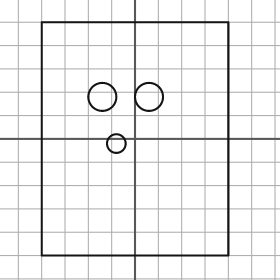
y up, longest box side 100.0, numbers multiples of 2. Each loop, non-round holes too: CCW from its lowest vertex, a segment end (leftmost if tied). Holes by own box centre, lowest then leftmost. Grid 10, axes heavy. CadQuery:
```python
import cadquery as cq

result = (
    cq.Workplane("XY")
    .moveTo(-40.0, -50.0)
    .lineTo(40.0, -50.0)
    .lineTo(40.0, 50.0)
    .lineTo(-40.0, 50.0)
    .close()
    .moveTo(-8.0, -2.0)
    .circle(4.0)
    .moveTo(-14.0, 18.0)
    .circle(6.0)
    .moveTo(6.0, 18.0)
    .circle(6.0)
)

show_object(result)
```